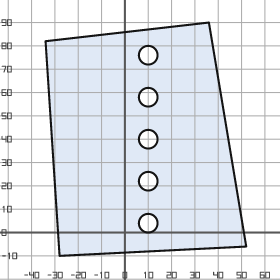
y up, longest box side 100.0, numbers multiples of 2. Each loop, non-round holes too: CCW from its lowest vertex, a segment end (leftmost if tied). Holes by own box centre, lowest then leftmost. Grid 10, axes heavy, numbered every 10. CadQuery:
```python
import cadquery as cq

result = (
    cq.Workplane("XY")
    .moveTo(-28.0, -10.0)
    .lineTo(52.0, -6.0)
    .lineTo(36.0, 90.0)
    .lineTo(-34.0, 82.0)
    .close()
    .moveTo(10.0, 4.0)
    .circle(4.0)
    .moveTo(10.0, 22.0)
    .circle(4.0)
    .moveTo(10.0, 40.0)
    .circle(4.0)
    .moveTo(10.0, 58.0)
    .circle(4.0)
    .moveTo(10.0, 76.0)
    .circle(4.0)
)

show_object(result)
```